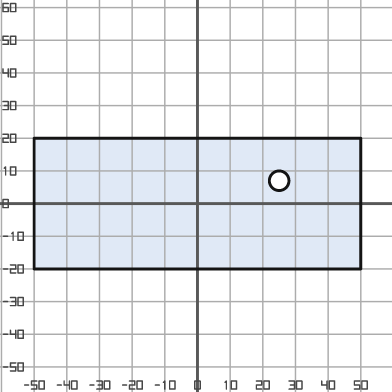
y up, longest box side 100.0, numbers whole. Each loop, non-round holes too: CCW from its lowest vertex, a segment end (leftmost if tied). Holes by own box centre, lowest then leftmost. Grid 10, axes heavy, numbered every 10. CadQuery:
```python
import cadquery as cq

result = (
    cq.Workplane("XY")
    .moveTo(-50.0, -20.0)
    .lineTo(50.0, -20.0)
    .lineTo(50.0, 20.0)
    .lineTo(-50.0, 20.0)
    .close()
    .moveTo(25.0, 7.0)
    .circle(3.0)
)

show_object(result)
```